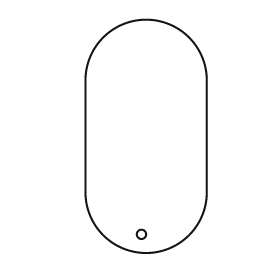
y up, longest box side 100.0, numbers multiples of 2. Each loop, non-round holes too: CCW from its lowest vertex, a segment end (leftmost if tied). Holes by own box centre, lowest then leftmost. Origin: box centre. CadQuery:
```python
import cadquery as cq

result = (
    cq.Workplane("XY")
    .moveTo(-26.0, -24.0)
    .threePointArc((0.0, -50.0), (26.0, -24.0))
    .lineTo(26.0, 24.0)
    .threePointArc((0.0, 50.0), (-26.0, 24.0))
    .close()
    .moveTo(-2.0, -42.0)
    .circle(2.0)
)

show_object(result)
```